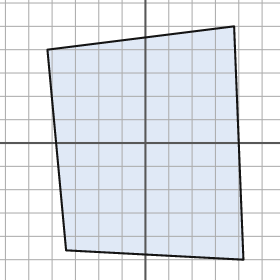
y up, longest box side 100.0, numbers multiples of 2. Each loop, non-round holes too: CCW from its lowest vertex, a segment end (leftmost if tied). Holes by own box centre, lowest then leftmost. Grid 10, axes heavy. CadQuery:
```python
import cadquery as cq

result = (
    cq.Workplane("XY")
    .moveTo(42.0, -50.0)
    .lineTo(38.0, 50.0)
    .lineTo(-42.0, 40.0)
    .lineTo(-34.0, -46.0)
    .close()
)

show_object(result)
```